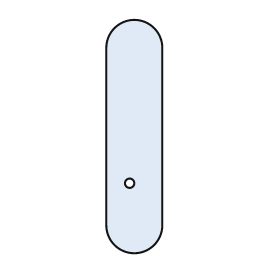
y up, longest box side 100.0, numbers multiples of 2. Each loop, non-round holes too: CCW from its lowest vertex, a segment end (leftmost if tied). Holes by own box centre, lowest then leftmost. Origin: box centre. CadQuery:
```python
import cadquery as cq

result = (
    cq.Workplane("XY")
    .moveTo(-12.0, -38.0)
    .threePointArc((0.0, -50.0), (12.0, -38.0))
    .lineTo(12.0, 38.0)
    .threePointArc((0.0, 50.0), (-12.0, 38.0))
    .close()
    .moveTo(-2.0, -20.0)
    .circle(2.0)
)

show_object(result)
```